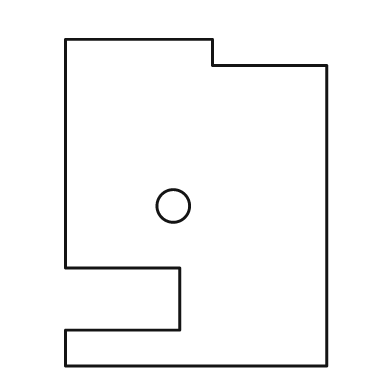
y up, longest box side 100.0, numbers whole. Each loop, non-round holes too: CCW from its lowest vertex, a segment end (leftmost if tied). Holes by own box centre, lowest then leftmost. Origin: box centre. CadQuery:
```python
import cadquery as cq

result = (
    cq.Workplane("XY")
    .moveTo(-40.0, -50.0)
    .lineTo(40.0, -50.0)
    .lineTo(40.0, 42.0)
    .lineTo(5.0, 42.0)
    .lineTo(5.0, 50.0)
    .lineTo(-40.0, 50.0)
    .lineTo(-40.0, -20.0)
    .lineTo(-5.0, -20.0)
    .lineTo(-5.0, -39.0)
    .lineTo(-40.0, -39.0)
    .close()
    .moveTo(-7.0, -1.0)
    .circle(5.0)
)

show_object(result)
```